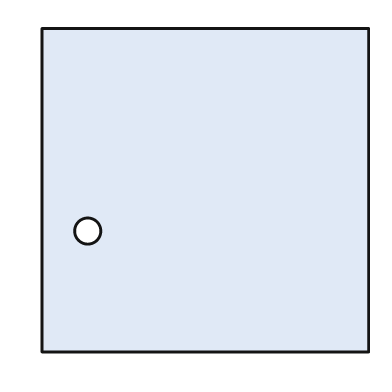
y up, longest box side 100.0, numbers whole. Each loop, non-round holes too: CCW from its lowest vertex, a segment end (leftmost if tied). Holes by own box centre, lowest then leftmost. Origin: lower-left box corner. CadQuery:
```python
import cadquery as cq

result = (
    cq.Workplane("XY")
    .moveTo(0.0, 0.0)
    .lineTo(100.0, 0.0)
    .lineTo(100.0, 99.0)
    .lineTo(0.0, 99.0)
    .close()
    .moveTo(14.0, 37.0)
    .circle(4.0)
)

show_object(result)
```